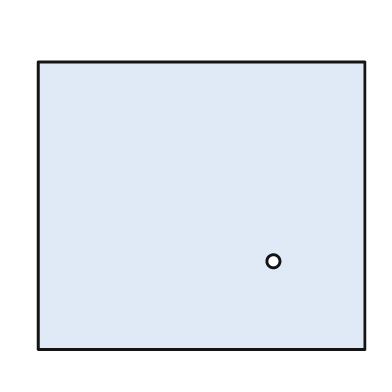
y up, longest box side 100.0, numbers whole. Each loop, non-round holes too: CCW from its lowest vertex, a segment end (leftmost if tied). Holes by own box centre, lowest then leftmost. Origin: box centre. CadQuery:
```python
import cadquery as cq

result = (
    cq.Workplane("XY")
    .moveTo(-50.0, -44.0)
    .lineTo(50.0, -44.0)
    .lineTo(50.0, 44.0)
    .lineTo(-50.0, 44.0)
    .close()
    .moveTo(22.0, -17.0)
    .circle(2.0)
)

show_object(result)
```